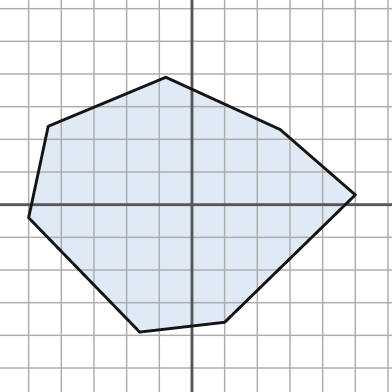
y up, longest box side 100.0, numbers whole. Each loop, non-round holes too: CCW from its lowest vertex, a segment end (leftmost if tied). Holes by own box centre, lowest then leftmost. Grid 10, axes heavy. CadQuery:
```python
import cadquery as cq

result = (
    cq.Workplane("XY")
    .moveTo(-16.0, -39.0)
    .lineTo(10.0, -36.0)
    .lineTo(50.0, 3.0)
    .lineTo(27.0, 23.0)
    .lineTo(-8.0, 39.0)
    .lineTo(-44.0, 24.0)
    .lineTo(-50.0, -4.0)
    .close()
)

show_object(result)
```